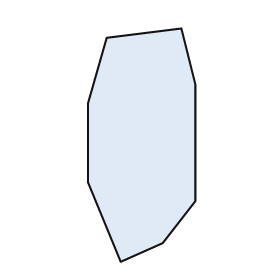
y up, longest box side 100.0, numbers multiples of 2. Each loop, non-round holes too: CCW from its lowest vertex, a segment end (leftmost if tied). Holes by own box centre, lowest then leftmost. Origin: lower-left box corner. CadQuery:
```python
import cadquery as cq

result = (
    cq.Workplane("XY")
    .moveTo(14.0, 0.0)
    .lineTo(32.0, 8.0)
    .lineTo(46.0, 26.0)
    .lineTo(46.0, 76.0)
    .lineTo(40.0, 100.0)
    .lineTo(8.0, 96.0)
    .lineTo(0.0, 68.0)
    .lineTo(0.0, 34.0)
    .close()
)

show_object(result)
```